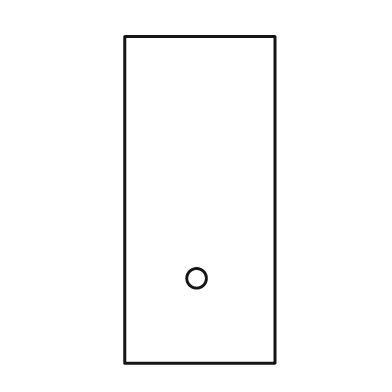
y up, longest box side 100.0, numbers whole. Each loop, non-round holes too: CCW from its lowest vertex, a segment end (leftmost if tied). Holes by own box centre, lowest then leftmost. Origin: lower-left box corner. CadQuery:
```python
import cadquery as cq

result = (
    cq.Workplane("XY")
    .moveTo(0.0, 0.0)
    .lineTo(46.0, 0.0)
    .lineTo(46.0, 100.0)
    .lineTo(0.0, 100.0)
    .close()
    .moveTo(22.0, 26.0)
    .circle(3.0)
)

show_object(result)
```